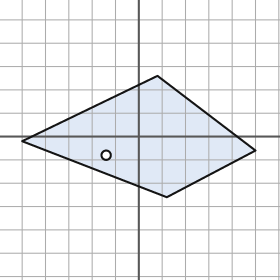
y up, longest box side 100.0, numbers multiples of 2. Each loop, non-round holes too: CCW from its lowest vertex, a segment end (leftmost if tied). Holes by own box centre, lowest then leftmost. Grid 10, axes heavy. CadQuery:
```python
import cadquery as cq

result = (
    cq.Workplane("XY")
    .moveTo(12.0, -26.0)
    .lineTo(50.0, -6.0)
    .lineTo(8.0, 26.0)
    .lineTo(-50.0, -2.0)
    .close()
    .moveTo(-14.0, -8.0)
    .circle(2.0)
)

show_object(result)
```